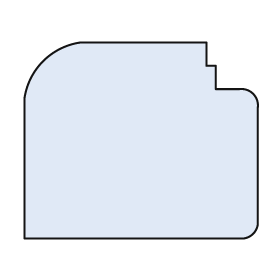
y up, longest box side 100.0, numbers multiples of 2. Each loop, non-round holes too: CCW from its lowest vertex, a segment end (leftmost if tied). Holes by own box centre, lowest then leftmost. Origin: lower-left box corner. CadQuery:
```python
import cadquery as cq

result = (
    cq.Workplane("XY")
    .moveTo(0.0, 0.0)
    .lineTo(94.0, 0.0)
    .threePointArc((98.0, 2.0), (100.0, 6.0))
    .lineTo(100.0, 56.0)
    .threePointArc((98.0, 62.0), (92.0, 64.0))
    .lineTo(82.0, 64.0)
    .lineTo(82.0, 74.0)
    .lineTo(78.0, 74.0)
    .lineTo(78.0, 84.0)
    .lineTo(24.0, 84.0)
    .threePointArc((8.0, 76.0), (0.0, 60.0))
    .close()
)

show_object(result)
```